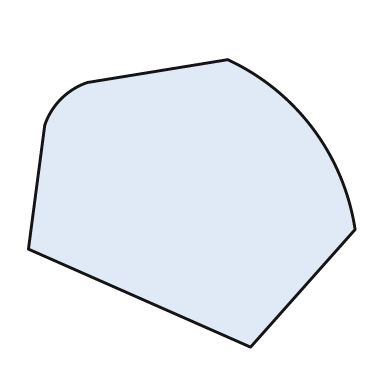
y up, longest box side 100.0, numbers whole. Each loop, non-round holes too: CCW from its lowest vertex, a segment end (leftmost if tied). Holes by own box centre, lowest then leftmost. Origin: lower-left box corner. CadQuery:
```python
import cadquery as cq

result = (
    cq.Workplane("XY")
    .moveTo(68.0, 0.0)
    .lineTo(100.0, 36.0)
    .threePointArc((87.0, 67.0), (61.0, 88.0))
    .lineTo(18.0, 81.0)
    .threePointArc((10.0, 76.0), (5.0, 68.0))
    .lineTo(0.0, 30.0)
    .close()
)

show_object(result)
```